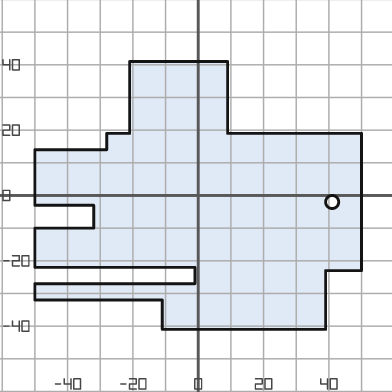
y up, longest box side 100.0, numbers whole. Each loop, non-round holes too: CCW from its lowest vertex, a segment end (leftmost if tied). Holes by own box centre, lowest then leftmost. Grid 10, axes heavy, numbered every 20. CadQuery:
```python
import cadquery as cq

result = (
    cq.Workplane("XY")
    .moveTo(-11.0, -41.0)
    .lineTo(39.0, -41.0)
    .lineTo(39.0, -23.0)
    .lineTo(50.0, -23.0)
    .lineTo(50.0, 19.0)
    .lineTo(9.0, 19.0)
    .lineTo(9.0, 41.0)
    .lineTo(-21.0, 41.0)
    .lineTo(-21.0, 19.0)
    .lineTo(-28.0, 19.0)
    .lineTo(-28.0, 14.0)
    .lineTo(-50.0, 14.0)
    .lineTo(-50.0, -3.0)
    .lineTo(-32.0, -3.0)
    .lineTo(-32.0, -10.0)
    .lineTo(-50.0, -10.0)
    .lineTo(-50.0, -22.0)
    .lineTo(-1.0, -22.0)
    .lineTo(-1.0, -27.0)
    .lineTo(-50.0, -27.0)
    .lineTo(-50.0, -32.0)
    .lineTo(-11.0, -32.0)
    .close()
    .moveTo(41.0, -2.0)
    .circle(2.0)
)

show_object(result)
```